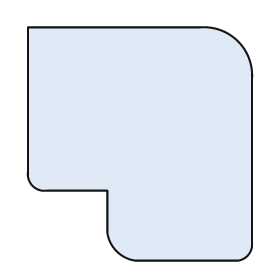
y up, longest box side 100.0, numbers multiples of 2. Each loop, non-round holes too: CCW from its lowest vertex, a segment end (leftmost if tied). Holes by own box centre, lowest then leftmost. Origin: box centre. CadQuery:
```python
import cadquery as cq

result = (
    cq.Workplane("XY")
    .moveTo(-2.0, -50.0)
    .lineTo(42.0, -50.0)
    .threePointArc((46.0, -48.0), (48.0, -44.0))
    .lineTo(48.0, 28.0)
    .threePointArc((42.0, 44.0), (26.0, 50.0))
    .lineTo(-48.0, 50.0)
    .lineTo(-48.0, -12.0)
    .threePointArc((-46.0, -18.0), (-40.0, -20.0))
    .lineTo(-14.0, -20.0)
    .lineTo(-14.0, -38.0)
    .threePointArc((-10.0, -46.0), (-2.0, -50.0))
    .close()
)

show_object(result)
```